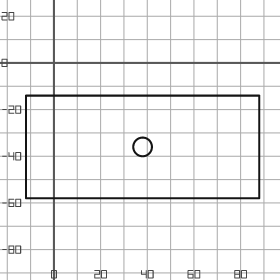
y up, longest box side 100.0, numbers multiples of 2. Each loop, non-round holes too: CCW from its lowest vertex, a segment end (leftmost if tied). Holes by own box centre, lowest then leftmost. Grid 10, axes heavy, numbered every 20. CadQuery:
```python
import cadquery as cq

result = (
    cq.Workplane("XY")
    .moveTo(-12.0, -58.0)
    .lineTo(88.0, -58.0)
    .lineTo(88.0, -14.0)
    .lineTo(-12.0, -14.0)
    .close()
    .moveTo(38.0, -36.0)
    .circle(4.0)
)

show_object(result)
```